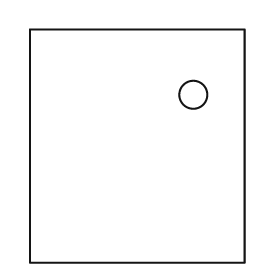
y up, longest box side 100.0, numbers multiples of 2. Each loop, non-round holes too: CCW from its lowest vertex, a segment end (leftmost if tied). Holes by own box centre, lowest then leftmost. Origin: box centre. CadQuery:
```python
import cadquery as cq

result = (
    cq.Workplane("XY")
    .moveTo(-46.0, -50.0)
    .lineTo(46.0, -50.0)
    .lineTo(46.0, 50.0)
    .lineTo(-46.0, 50.0)
    .close()
    .moveTo(24.0, 22.0)
    .circle(6.0)
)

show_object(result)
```